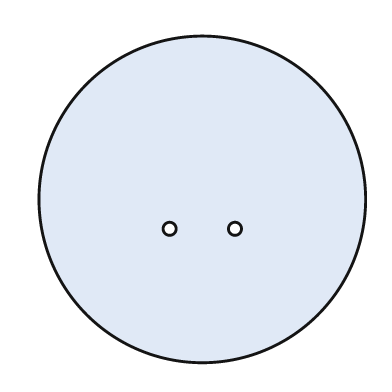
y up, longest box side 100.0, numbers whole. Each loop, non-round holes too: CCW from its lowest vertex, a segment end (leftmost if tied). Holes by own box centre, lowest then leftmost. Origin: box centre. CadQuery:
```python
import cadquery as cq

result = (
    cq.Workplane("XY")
    .moveTo(0.0, 0.0)
    .circle(50.0)
    .moveTo(-10.0, -9.0)
    .circle(2.0)
    .moveTo(10.0, -9.0)
    .circle(2.0)
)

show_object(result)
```